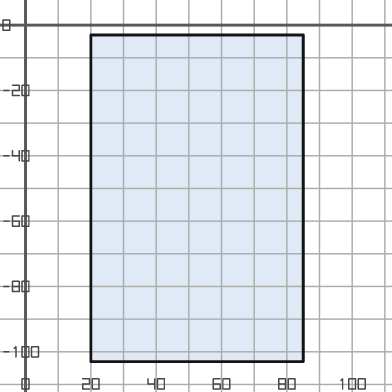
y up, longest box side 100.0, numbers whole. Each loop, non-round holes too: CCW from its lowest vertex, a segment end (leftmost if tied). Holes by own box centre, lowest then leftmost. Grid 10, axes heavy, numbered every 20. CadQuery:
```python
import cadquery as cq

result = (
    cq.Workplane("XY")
    .moveTo(20.0, -103.0)
    .lineTo(85.0, -103.0)
    .lineTo(85.0, -3.0)
    .lineTo(20.0, -3.0)
    .close()
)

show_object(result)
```